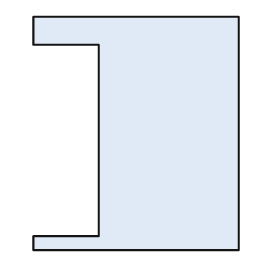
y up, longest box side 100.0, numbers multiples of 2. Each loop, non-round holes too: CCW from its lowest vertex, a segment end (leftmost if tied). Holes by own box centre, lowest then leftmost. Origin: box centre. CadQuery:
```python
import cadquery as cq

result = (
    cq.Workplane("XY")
    .moveTo(-44.0, -50.0)
    .lineTo(44.0, -50.0)
    .lineTo(44.0, 50.0)
    .lineTo(-44.0, 50.0)
    .lineTo(-44.0, 38.0)
    .lineTo(-16.0, 38.0)
    .lineTo(-16.0, -44.0)
    .lineTo(-44.0, -44.0)
    .close()
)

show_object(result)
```